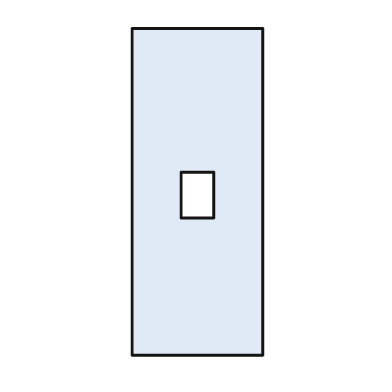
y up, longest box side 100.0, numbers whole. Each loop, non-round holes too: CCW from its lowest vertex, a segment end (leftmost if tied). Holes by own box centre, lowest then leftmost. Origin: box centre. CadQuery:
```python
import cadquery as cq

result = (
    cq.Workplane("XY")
    .moveTo(-20.0, -50.0)
    .lineTo(20.0, -50.0)
    .lineTo(20.0, 50.0)
    .lineTo(-20.0, 50.0)
    .close()
    .moveTo(-5.0, -8.0)
    .lineTo(5.0, -8.0)
    .lineTo(5.0, 6.0)
    .lineTo(-5.0, 6.0)
    .close()
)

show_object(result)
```